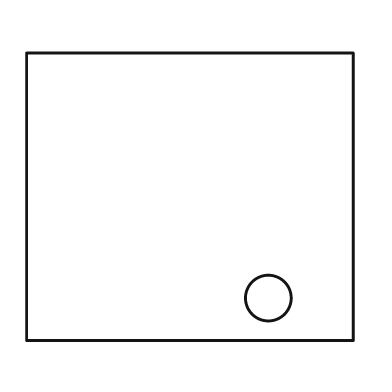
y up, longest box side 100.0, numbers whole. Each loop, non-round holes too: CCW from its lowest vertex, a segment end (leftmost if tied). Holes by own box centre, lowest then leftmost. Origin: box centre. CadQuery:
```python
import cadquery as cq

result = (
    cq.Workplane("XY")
    .moveTo(-50.0, -44.0)
    .lineTo(50.0, -44.0)
    .lineTo(50.0, 44.0)
    .lineTo(-50.0, 44.0)
    .close()
    .moveTo(24.0, -31.0)
    .circle(7.0)
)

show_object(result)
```